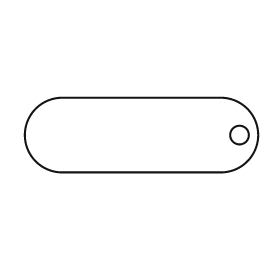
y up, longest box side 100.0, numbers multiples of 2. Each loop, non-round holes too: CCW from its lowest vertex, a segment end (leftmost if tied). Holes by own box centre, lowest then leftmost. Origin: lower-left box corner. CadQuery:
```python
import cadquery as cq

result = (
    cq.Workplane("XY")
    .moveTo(16.0, 0.0)
    .lineTo(84.0, 0.0)
    .threePointArc((100.0, 16.0), (84.0, 32.0))
    .lineTo(16.0, 32.0)
    .threePointArc((0.0, 16.0), (16.0, 0.0))
    .close()
    .moveTo(92.0, 16.0)
    .circle(4.0)
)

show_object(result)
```